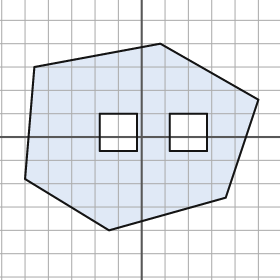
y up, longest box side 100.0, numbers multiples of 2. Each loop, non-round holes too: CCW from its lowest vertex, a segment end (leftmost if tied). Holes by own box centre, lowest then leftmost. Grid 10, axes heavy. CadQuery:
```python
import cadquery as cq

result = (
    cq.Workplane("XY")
    .moveTo(-14.0, -40.0)
    .lineTo(36.0, -26.0)
    .lineTo(50.0, 16.0)
    .lineTo(8.0, 40.0)
    .lineTo(-46.0, 30.0)
    .lineTo(-50.0, -18.0)
    .close()
    .moveTo(-18.0, -6.0)
    .lineTo(-2.0, -6.0)
    .lineTo(-2.0, 10.0)
    .lineTo(-18.0, 10.0)
    .close()
    .moveTo(12.0, -6.0)
    .lineTo(28.0, -6.0)
    .lineTo(28.0, 10.0)
    .lineTo(12.0, 10.0)
    .close()
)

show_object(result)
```